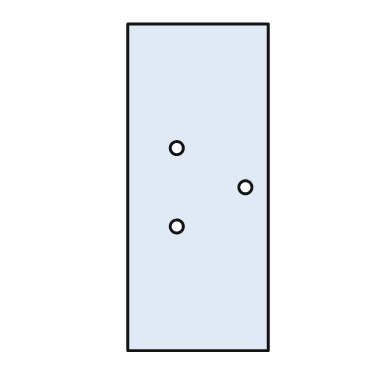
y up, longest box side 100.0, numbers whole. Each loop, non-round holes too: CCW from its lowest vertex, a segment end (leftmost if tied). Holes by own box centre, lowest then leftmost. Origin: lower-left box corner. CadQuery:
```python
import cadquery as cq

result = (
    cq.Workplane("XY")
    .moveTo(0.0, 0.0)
    .lineTo(43.0, 0.0)
    .lineTo(43.0, 100.0)
    .lineTo(0.0, 100.0)
    .close()
    .moveTo(15.0, 38.0)
    .circle(2.0)
    .moveTo(36.0, 50.0)
    .circle(2.0)
    .moveTo(15.0, 62.0)
    .circle(2.0)
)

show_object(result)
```